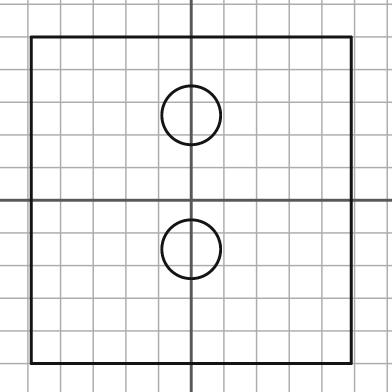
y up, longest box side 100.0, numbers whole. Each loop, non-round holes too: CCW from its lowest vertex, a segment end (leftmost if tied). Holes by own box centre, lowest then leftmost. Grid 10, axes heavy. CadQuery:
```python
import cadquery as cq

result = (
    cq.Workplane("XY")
    .moveTo(-49.0, -50.0)
    .lineTo(49.0, -50.0)
    .lineTo(49.0, 50.0)
    .lineTo(-49.0, 50.0)
    .close()
    .moveTo(0.0, -15.0)
    .circle(9.0)
    .moveTo(0.0, 26.0)
    .circle(9.0)
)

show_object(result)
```